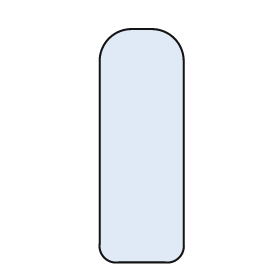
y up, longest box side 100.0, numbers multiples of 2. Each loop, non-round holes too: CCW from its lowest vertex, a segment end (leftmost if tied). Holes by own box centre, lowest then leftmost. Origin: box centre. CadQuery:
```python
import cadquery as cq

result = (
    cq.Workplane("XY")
    .moveTo(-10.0, -50.0)
    .lineTo(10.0, -50.0)
    .threePointArc((16.0, -48.0), (18.0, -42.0))
    .lineTo(18.0, 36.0)
    .threePointArc((14.0, 46.0), (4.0, 50.0))
    .lineTo(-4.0, 50.0)
    .threePointArc((-14.0, 46.0), (-18.0, 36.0))
    .lineTo(-18.0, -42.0)
    .threePointArc((-16.0, -48.0), (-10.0, -50.0))
    .close()
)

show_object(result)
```